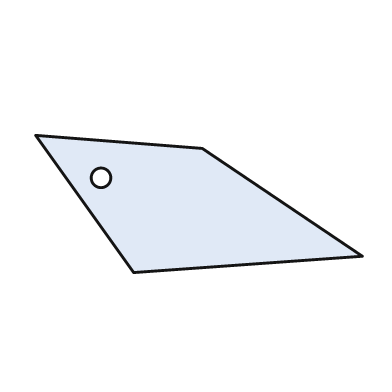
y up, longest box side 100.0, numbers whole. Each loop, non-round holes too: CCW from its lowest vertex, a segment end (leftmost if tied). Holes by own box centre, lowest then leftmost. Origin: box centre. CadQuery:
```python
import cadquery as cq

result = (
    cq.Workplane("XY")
    .moveTo(-20.0, -21.0)
    .lineTo(50.0, -16.0)
    .lineTo(1.0, 17.0)
    .lineTo(-50.0, 21.0)
    .close()
    .moveTo(-30.0, 8.0)
    .circle(3.0)
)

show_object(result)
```